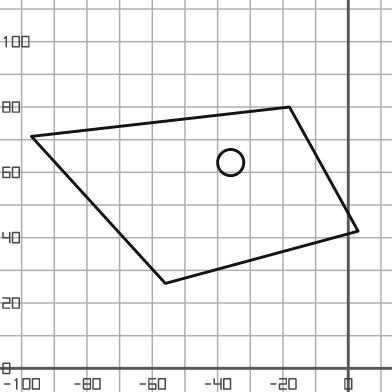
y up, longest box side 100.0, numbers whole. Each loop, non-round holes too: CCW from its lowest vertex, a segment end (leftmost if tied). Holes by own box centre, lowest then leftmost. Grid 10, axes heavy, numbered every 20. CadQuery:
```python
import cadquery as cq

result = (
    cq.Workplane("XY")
    .moveTo(-56.0, 26.0)
    .lineTo(3.0, 42.0)
    .lineTo(-18.0, 80.0)
    .lineTo(-97.0, 71.0)
    .close()
    .moveTo(-36.0, 63.0)
    .circle(4.0)
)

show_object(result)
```